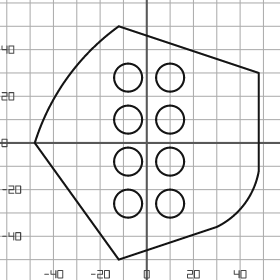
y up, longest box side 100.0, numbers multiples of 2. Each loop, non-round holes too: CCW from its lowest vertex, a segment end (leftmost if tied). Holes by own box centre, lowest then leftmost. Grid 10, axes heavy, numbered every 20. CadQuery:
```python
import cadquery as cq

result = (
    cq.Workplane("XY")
    .moveTo(-12.0, -50.0)
    .lineTo(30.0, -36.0)
    .threePointArc((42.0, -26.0), (48.0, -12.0))
    .lineTo(48.0, 30.0)
    .lineTo(-12.0, 50.0)
    .threePointArc((-34.0, 28.0), (-48.0, 0.0))
    .close()
    .moveTo(-8.0, -26.0)
    .circle(6.0)
    .moveTo(10.0, -26.0)
    .circle(6.0)
    .moveTo(-8.0, -8.0)
    .circle(6.0)
    .moveTo(10.0, -8.0)
    .circle(6.0)
    .moveTo(-8.0, 10.0)
    .circle(6.0)
    .moveTo(10.0, 10.0)
    .circle(6.0)
    .moveTo(-8.0, 28.0)
    .circle(6.0)
    .moveTo(10.0, 28.0)
    .circle(6.0)
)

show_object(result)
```